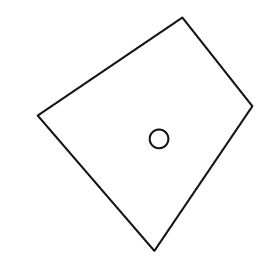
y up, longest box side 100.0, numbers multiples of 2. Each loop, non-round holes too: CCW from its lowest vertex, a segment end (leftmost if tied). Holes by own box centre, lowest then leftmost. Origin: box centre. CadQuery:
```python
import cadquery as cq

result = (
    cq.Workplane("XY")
    .moveTo(4.0, -50.0)
    .lineTo(46.0, 12.0)
    .lineTo(16.0, 50.0)
    .lineTo(-46.0, 8.0)
    .close()
    .moveTo(6.0, -2.0)
    .circle(4.0)
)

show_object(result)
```